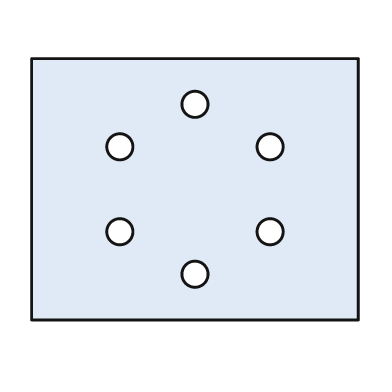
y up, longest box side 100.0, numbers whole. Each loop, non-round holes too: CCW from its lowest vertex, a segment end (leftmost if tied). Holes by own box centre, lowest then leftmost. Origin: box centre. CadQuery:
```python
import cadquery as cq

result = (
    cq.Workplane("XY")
    .moveTo(-50.0, -40.0)
    .lineTo(50.0, -40.0)
    .lineTo(50.0, 40.0)
    .lineTo(-50.0, 40.0)
    .close()
    .moveTo(0.0, -26.0)
    .circle(4.0)
    .moveTo(-23.0, -13.0)
    .circle(4.0)
    .moveTo(23.0, -13.0)
    .circle(4.0)
    .moveTo(-23.0, 13.0)
    .circle(4.0)
    .moveTo(23.0, 13.0)
    .circle(4.0)
    .moveTo(0.0, 26.0)
    .circle(4.0)
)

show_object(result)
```